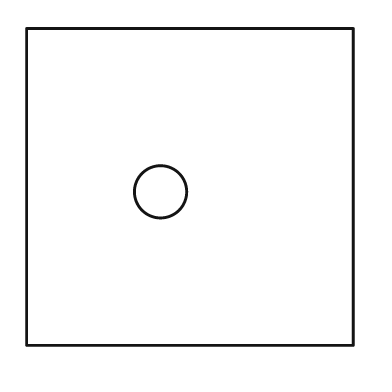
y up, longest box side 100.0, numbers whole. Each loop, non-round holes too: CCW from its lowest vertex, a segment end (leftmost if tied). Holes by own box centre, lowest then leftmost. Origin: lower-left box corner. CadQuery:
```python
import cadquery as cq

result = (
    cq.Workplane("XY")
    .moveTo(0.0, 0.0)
    .lineTo(100.0, 0.0)
    .lineTo(100.0, 97.0)
    .lineTo(0.0, 97.0)
    .close()
    .moveTo(41.0, 47.0)
    .circle(8.0)
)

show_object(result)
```